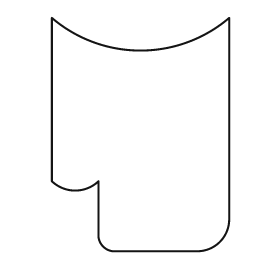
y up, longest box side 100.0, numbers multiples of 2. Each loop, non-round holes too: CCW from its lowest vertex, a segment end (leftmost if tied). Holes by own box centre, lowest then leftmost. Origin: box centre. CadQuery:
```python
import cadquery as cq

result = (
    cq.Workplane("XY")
    .moveTo(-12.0, -50.0)
    .lineTo(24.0, -50.0)
    .threePointArc((34.0, -46.0), (38.0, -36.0))
    .lineTo(38.0, 50.0)
    .threePointArc((0.0, 36.0), (-38.0, 50.0))
    .lineTo(-38.0, -20.0)
    .threePointArc((-28.0, -24.0), (-18.0, -20.0))
    .lineTo(-18.0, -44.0)
    .threePointArc((-16.0, -48.0), (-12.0, -50.0))
    .close()
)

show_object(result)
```